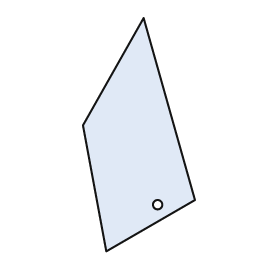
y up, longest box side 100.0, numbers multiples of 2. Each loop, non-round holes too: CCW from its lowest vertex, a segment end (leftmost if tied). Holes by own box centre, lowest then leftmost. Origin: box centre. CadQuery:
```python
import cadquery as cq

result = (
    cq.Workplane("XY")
    .moveTo(-14.0, -50.0)
    .lineTo(24.0, -28.0)
    .lineTo(2.0, 50.0)
    .lineTo(-24.0, 4.0)
    .close()
    .moveTo(8.0, -30.0)
    .circle(2.0)
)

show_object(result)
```